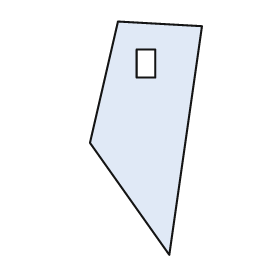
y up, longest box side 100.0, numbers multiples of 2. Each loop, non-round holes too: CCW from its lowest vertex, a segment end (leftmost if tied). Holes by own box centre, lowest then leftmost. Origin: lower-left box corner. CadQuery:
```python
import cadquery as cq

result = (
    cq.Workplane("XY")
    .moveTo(34.0, 0.0)
    .lineTo(48.0, 98.0)
    .lineTo(12.0, 100.0)
    .lineTo(0.0, 48.0)
    .close()
    .moveTo(20.0, 76.0)
    .lineTo(28.0, 76.0)
    .lineTo(28.0, 88.0)
    .lineTo(20.0, 88.0)
    .close()
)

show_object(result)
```